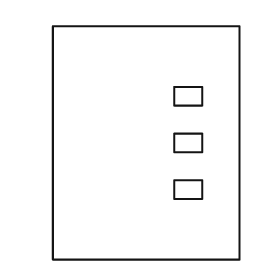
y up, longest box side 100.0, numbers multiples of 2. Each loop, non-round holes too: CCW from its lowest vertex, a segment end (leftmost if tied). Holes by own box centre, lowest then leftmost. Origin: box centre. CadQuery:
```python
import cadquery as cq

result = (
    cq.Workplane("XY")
    .moveTo(-40.0, -50.0)
    .lineTo(40.0, -50.0)
    .lineTo(40.0, 50.0)
    .lineTo(-40.0, 50.0)
    .close()
    .moveTo(12.0, -24.0)
    .lineTo(24.0, -24.0)
    .lineTo(24.0, -16.0)
    .lineTo(12.0, -16.0)
    .close()
    .moveTo(12.0, -4.0)
    .lineTo(24.0, -4.0)
    .lineTo(24.0, 4.0)
    .lineTo(12.0, 4.0)
    .close()
    .moveTo(12.0, 16.0)
    .lineTo(24.0, 16.0)
    .lineTo(24.0, 24.0)
    .lineTo(12.0, 24.0)
    .close()
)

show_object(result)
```